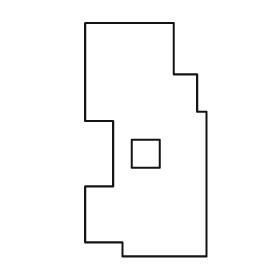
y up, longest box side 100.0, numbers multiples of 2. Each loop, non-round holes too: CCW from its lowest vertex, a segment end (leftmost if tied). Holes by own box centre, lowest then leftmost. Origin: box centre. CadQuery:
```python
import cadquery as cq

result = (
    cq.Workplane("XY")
    .moveTo(-10.0, -50.0)
    .lineTo(26.0, -50.0)
    .lineTo(26.0, 12.0)
    .lineTo(22.0, 12.0)
    .lineTo(22.0, 28.0)
    .lineTo(12.0, 28.0)
    .lineTo(12.0, 50.0)
    .lineTo(-26.0, 50.0)
    .lineTo(-26.0, 8.0)
    .lineTo(-14.0, 8.0)
    .lineTo(-14.0, -20.0)
    .lineTo(-26.0, -20.0)
    .lineTo(-26.0, -44.0)
    .lineTo(-10.0, -44.0)
    .close()
    .moveTo(-6.0, -12.0)
    .lineTo(6.0, -12.0)
    .lineTo(6.0, 0.0)
    .lineTo(-6.0, 0.0)
    .close()
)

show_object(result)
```